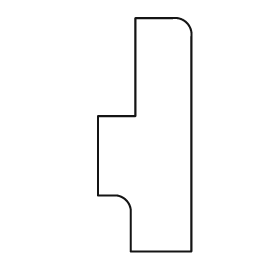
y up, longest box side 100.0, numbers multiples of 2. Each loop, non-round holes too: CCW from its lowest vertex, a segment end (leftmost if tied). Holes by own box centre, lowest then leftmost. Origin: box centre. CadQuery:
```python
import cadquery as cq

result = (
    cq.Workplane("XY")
    .moveTo(-6.0, -50.0)
    .lineTo(20.0, -50.0)
    .lineTo(20.0, 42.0)
    .threePointArc((18.0, 48.0), (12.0, 50.0))
    .lineTo(-4.0, 50.0)
    .lineTo(-4.0, 8.0)
    .lineTo(-20.0, 8.0)
    .lineTo(-20.0, -26.0)
    .lineTo(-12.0, -26.0)
    .threePointArc((-8.0, -28.0), (-6.0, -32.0))
    .close()
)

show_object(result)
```